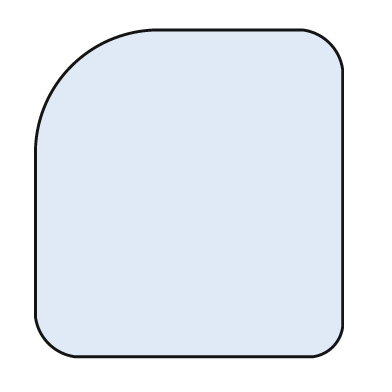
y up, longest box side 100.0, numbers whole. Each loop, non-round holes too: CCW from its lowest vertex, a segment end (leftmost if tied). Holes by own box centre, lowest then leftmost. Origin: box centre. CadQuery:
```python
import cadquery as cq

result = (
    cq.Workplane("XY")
    .moveTo(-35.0, -50.0)
    .lineTo(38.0, -50.0)
    .threePointArc((44.0, -47.0), (47.0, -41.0))
    .lineTo(47.0, 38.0)
    .threePointArc((43.0, 46.0), (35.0, 50.0))
    .lineTo(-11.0, 50.0)
    .threePointArc((-36.0, 39.0), (-47.0, 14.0))
    .lineTo(-47.0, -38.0)
    .threePointArc((-43.0, -46.0), (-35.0, -50.0))
    .close()
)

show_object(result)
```